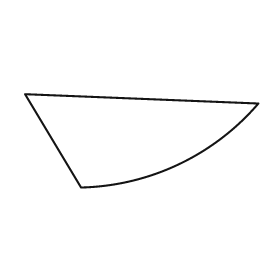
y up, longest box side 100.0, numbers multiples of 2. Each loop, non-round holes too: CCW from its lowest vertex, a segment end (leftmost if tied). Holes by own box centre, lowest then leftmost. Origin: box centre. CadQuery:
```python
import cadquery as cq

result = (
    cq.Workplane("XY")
    .moveTo(-26.0, -20.0)
    .threePointArc((16.0, -10.0), (50.0, 16.0))
    .lineTo(-50.0, 20.0)
    .close()
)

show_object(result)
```